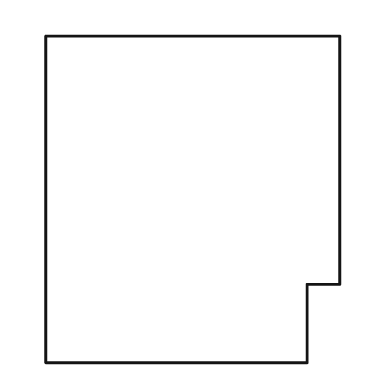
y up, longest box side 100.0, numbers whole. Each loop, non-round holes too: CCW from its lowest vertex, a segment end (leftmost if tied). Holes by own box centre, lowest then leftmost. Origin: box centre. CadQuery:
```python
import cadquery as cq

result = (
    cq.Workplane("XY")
    .moveTo(-45.0, -50.0)
    .lineTo(35.0, -50.0)
    .lineTo(35.0, -26.0)
    .lineTo(45.0, -26.0)
    .lineTo(45.0, 50.0)
    .lineTo(-45.0, 50.0)
    .close()
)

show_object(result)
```